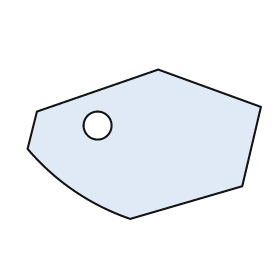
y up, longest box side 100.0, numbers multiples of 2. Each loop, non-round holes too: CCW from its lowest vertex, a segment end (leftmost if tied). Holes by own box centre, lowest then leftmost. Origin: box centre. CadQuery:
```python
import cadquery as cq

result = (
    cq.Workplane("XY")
    .moveTo(-6.0, -32.0)
    .lineTo(42.0, -18.0)
    .lineTo(50.0, 16.0)
    .lineTo(6.0, 32.0)
    .lineTo(-46.0, 14.0)
    .lineTo(-50.0, -2.0)
    .threePointArc((-30.0, -20.0), (-6.0, -32.0))
    .close()
    .moveTo(-20.0, 8.0)
    .circle(6.0)
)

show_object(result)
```